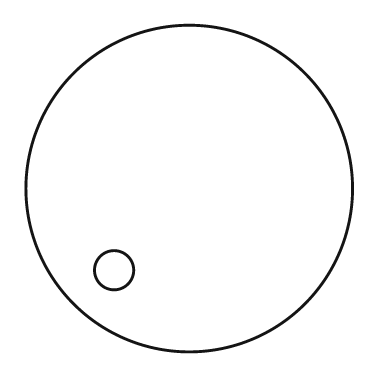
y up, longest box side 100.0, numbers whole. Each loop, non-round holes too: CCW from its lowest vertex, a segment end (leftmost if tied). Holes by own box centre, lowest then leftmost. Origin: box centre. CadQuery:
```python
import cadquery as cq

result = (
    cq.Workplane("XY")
    .moveTo(0.0, 0.0)
    .circle(50.0)
    .moveTo(-23.0, -25.0)
    .circle(6.0)
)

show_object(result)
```